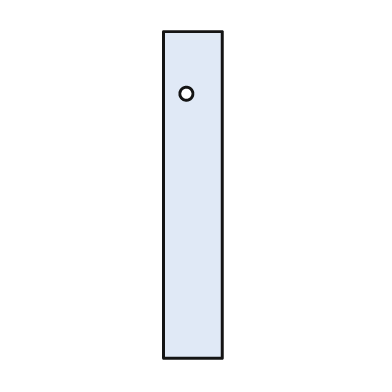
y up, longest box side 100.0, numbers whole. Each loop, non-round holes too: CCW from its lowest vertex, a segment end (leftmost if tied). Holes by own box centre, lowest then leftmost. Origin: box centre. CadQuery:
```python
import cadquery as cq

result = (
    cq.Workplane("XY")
    .moveTo(-9.0, -50.0)
    .lineTo(9.0, -50.0)
    .lineTo(9.0, 50.0)
    .lineTo(-9.0, 50.0)
    .close()
    .moveTo(-2.0, 31.0)
    .circle(2.0)
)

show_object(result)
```